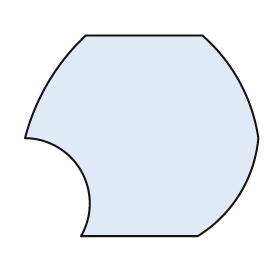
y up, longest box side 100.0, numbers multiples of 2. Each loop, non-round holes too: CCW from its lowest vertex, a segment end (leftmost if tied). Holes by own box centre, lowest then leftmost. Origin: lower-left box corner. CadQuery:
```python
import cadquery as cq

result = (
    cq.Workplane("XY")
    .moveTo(24.0, 0.0)
    .lineTo(74.0, 0.0)
    .threePointArc((92.0, 18.0), (100.0, 42.0))
    .threePointArc((92.0, 66.0), (76.0, 86.0))
    .lineTo(26.0, 86.0)
    .threePointArc((10.0, 66.0), (0.0, 42.0))
    .threePointArc((24.0, 28.0), (24.0, 0.0))
    .close()
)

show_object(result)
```